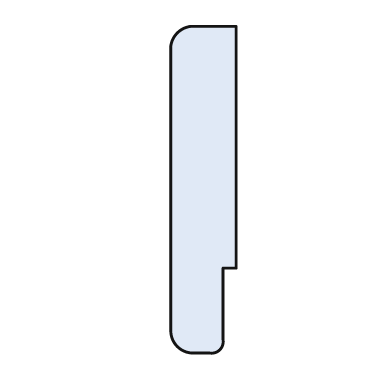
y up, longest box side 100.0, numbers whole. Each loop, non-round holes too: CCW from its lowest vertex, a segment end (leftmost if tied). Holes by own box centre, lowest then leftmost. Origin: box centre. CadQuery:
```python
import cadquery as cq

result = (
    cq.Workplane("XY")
    .moveTo(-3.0, -50.0)
    .lineTo(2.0, -50.0)
    .threePointArc((5.0, -49.0), (6.0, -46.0))
    .lineTo(6.0, -24.0)
    .lineTo(10.0, -24.0)
    .lineTo(10.0, 50.0)
    .lineTo(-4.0, 50.0)
    .threePointArc((-8.0, 48.0), (-10.0, 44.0))
    .lineTo(-10.0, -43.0)
    .threePointArc((-8.0, -48.0), (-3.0, -50.0))
    .close()
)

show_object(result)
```